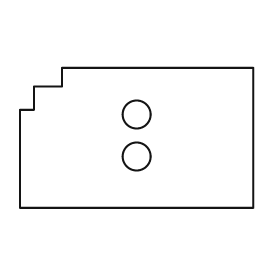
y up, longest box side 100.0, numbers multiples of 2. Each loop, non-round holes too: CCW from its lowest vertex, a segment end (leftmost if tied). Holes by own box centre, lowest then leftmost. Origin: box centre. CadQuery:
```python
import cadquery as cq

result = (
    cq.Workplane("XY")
    .moveTo(-50.0, -30.0)
    .lineTo(50.0, -30.0)
    .lineTo(50.0, 30.0)
    .lineTo(-32.0, 30.0)
    .lineTo(-32.0, 22.0)
    .lineTo(-44.0, 22.0)
    .lineTo(-44.0, 12.0)
    .lineTo(-50.0, 12.0)
    .close()
    .moveTo(0.0, -8.0)
    .circle(6.0)
    .moveTo(0.0, 10.0)
    .circle(6.0)
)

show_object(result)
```